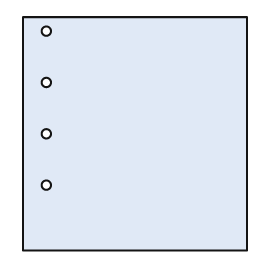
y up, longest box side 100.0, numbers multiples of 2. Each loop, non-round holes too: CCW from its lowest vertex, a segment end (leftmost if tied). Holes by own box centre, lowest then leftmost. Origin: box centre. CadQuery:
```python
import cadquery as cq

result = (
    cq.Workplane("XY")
    .moveTo(-48.0, -50.0)
    .lineTo(48.0, -50.0)
    .lineTo(48.0, 50.0)
    .lineTo(-48.0, 50.0)
    .close()
    .moveTo(-38.0, -22.0)
    .circle(2.0)
    .moveTo(-38.0, 0.0)
    .circle(2.0)
    .moveTo(-38.0, 22.0)
    .circle(2.0)
    .moveTo(-38.0, 44.0)
    .circle(2.0)
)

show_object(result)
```